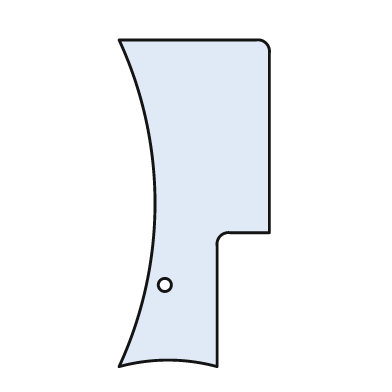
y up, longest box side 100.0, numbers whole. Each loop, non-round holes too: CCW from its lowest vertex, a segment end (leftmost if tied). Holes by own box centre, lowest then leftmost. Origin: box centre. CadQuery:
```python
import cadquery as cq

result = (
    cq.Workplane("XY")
    .moveTo(-23.0, -50.0)
    .threePointArc((-8.0, -48.0), (7.0, -50.0))
    .lineTo(7.0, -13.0)
    .threePointArc((8.0, -10.0), (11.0, -9.0))
    .lineTo(23.0, -9.0)
    .lineTo(23.0, 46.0)
    .threePointArc((22.0, 49.0), (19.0, 50.0))
    .lineTo(-23.0, 50.0)
    .threePointArc((-12.0, 0.0), (-23.0, -50.0))
    .close()
    .moveTo(-9.0, -25.0)
    .circle(2.0)
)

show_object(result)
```